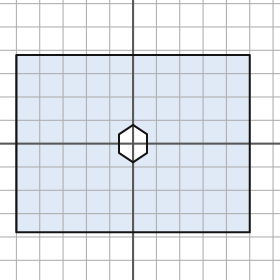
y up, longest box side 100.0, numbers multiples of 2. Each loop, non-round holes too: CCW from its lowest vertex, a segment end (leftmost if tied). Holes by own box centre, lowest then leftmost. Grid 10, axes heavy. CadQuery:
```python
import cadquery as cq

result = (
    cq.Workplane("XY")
    .moveTo(-50.0, -38.0)
    .lineTo(50.0, -38.0)
    .lineTo(50.0, 38.0)
    .lineTo(-50.0, 38.0)
    .close()
    .moveTo(0.0, -8.0)
    .lineTo(6.0, -4.0)
    .lineTo(6.0, 4.0)
    .lineTo(0.0, 8.0)
    .lineTo(-6.0, 4.0)
    .lineTo(-6.0, -4.0)
    .close()
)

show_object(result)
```